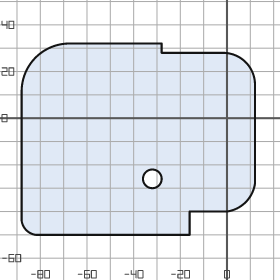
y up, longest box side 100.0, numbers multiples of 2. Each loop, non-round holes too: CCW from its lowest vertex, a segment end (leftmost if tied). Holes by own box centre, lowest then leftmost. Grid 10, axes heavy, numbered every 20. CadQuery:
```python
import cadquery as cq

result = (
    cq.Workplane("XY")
    .moveTo(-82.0, -50.0)
    .lineTo(-16.0, -50.0)
    .lineTo(-16.0, -40.0)
    .lineTo(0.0, -40.0)
    .threePointArc((8.0, -36.0), (12.0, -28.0))
    .lineTo(12.0, 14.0)
    .threePointArc((8.0, 24.0), (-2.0, 28.0))
    .lineTo(-28.0, 28.0)
    .lineTo(-28.0, 32.0)
    .lineTo(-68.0, 32.0)
    .threePointArc((-82.0, 26.0), (-88.0, 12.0))
    .lineTo(-88.0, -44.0)
    .threePointArc((-86.0, -48.0), (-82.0, -50.0))
    .close()
    .moveTo(-32.0, -26.0)
    .circle(4.0)
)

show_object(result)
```